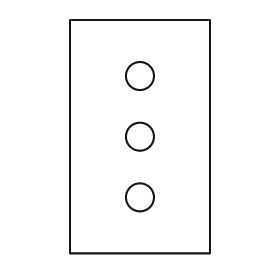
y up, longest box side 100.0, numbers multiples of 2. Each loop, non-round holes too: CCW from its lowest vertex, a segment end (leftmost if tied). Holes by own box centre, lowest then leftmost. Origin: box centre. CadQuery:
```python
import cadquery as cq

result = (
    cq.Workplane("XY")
    .moveTo(-30.0, -50.0)
    .lineTo(30.0, -50.0)
    .lineTo(30.0, 50.0)
    .lineTo(-30.0, 50.0)
    .close()
    .moveTo(0.0, -26.0)
    .circle(6.0)
    .moveTo(0.0, 0.0)
    .circle(6.0)
    .moveTo(0.0, 26.0)
    .circle(6.0)
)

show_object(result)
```